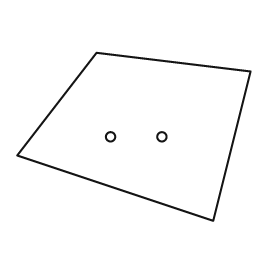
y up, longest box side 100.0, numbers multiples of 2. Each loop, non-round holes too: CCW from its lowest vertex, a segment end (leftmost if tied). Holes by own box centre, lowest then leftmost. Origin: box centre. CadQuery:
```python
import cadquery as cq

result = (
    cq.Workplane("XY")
    .moveTo(34.0, -36.0)
    .lineTo(50.0, 28.0)
    .lineTo(-16.0, 36.0)
    .lineTo(-50.0, -8.0)
    .close()
    .moveTo(-10.0, 0.0)
    .circle(2.0)
    .moveTo(12.0, 0.0)
    .circle(2.0)
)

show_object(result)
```